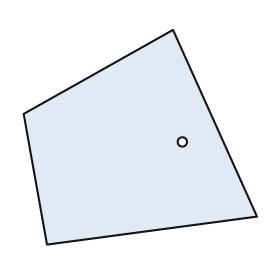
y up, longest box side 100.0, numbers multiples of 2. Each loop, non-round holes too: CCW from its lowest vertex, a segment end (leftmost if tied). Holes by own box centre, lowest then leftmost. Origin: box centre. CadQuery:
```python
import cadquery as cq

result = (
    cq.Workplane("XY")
    .moveTo(-40.0, -46.0)
    .lineTo(50.0, -34.0)
    .lineTo(14.0, 46.0)
    .lineTo(-50.0, 10.0)
    .close()
    .moveTo(18.0, -2.0)
    .circle(2.0)
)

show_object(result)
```